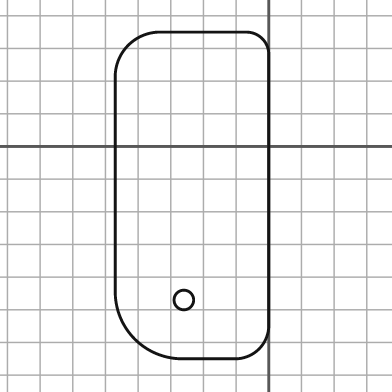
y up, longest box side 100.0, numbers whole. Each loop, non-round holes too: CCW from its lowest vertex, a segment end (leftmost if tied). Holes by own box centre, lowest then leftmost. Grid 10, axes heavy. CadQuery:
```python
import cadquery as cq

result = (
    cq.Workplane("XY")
    .moveTo(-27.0, -65.0)
    .lineTo(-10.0, -65.0)
    .threePointArc((-3.0, -62.0), (0.0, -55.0))
    .lineTo(0.0, 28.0)
    .threePointArc((-2.0, 33.0), (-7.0, 35.0))
    .lineTo(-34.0, 35.0)
    .threePointArc((-43.0, 31.0), (-47.0, 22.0))
    .lineTo(-47.0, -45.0)
    .threePointArc((-41.0, -59.0), (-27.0, -65.0))
    .close()
    .moveTo(-26.0, -47.0)
    .circle(3.0)
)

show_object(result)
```